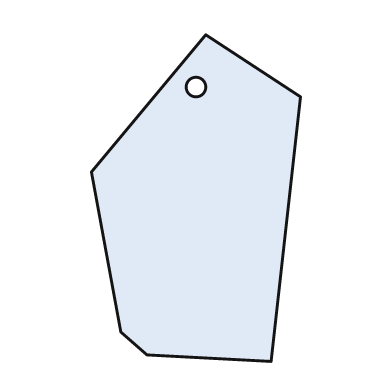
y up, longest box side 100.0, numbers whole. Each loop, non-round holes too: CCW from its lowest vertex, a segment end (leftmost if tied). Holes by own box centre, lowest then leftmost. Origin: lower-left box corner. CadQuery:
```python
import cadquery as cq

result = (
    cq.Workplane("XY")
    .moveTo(55.0, 0.0)
    .lineTo(64.0, 81.0)
    .lineTo(35.0, 100.0)
    .lineTo(0.0, 58.0)
    .lineTo(9.0, 9.0)
    .lineTo(17.0, 2.0)
    .close()
    .moveTo(32.0, 84.0)
    .circle(3.0)
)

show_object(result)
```